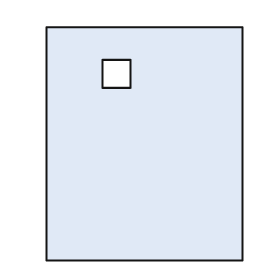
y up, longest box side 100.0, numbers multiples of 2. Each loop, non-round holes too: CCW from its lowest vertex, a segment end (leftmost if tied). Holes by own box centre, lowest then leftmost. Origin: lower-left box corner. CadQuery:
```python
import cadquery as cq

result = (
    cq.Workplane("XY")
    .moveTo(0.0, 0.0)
    .lineTo(84.0, 0.0)
    .lineTo(84.0, 100.0)
    .lineTo(0.0, 100.0)
    .close()
    .moveTo(24.0, 74.0)
    .lineTo(36.0, 74.0)
    .lineTo(36.0, 86.0)
    .lineTo(24.0, 86.0)
    .close()
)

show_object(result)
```